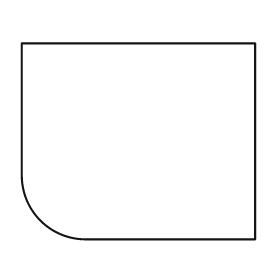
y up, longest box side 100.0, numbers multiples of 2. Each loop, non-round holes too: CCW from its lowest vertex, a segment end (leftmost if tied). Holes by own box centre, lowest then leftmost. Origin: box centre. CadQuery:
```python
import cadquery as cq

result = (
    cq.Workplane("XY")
    .moveTo(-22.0, -42.0)
    .lineTo(50.0, -42.0)
    .lineTo(50.0, 42.0)
    .lineTo(-50.0, 42.0)
    .lineTo(-50.0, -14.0)
    .threePointArc((-42.0, -34.0), (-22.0, -42.0))
    .close()
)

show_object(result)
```